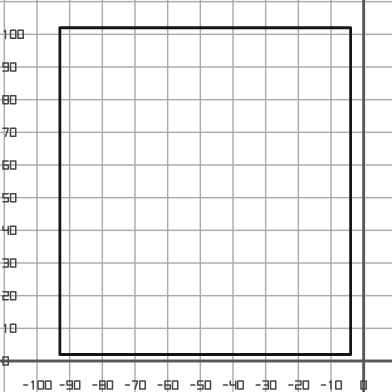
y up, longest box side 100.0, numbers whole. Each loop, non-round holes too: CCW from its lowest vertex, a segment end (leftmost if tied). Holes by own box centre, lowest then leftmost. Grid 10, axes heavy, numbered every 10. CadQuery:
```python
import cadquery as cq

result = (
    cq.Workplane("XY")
    .moveTo(-93.0, 2.0)
    .lineTo(-4.0, 2.0)
    .lineTo(-4.0, 102.0)
    .lineTo(-93.0, 102.0)
    .close()
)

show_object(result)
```